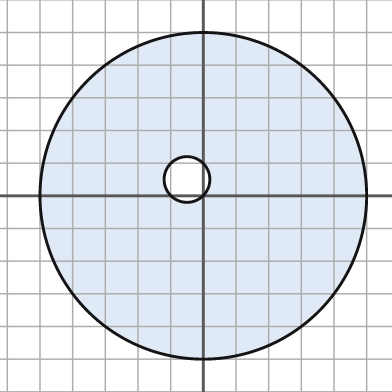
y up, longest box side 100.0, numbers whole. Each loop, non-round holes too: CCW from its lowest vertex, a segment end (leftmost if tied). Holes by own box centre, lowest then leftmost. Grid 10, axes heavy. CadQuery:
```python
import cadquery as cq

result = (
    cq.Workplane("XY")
    .moveTo(0.0, 0.0)
    .circle(50.0)
    .moveTo(-5.0, 5.0)
    .circle(7.0)
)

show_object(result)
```